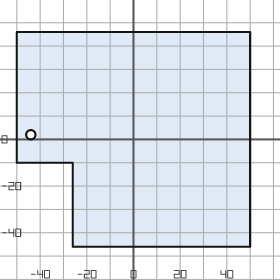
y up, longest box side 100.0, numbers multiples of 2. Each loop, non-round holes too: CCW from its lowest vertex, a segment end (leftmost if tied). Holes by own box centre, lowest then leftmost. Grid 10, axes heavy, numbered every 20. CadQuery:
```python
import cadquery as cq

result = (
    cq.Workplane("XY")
    .moveTo(-26.0, -46.0)
    .lineTo(50.0, -46.0)
    .lineTo(50.0, 46.0)
    .lineTo(-50.0, 46.0)
    .lineTo(-50.0, -10.0)
    .lineTo(-26.0, -10.0)
    .close()
    .moveTo(-44.0, 2.0)
    .circle(2.0)
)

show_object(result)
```